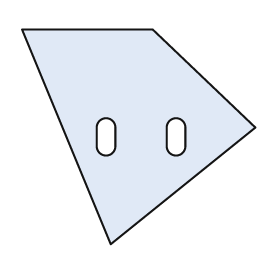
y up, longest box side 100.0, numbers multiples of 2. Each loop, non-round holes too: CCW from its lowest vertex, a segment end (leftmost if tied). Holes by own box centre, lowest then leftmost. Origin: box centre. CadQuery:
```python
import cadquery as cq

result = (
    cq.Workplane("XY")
    .moveTo(-12.0, -46.0)
    .lineTo(50.0, 4.0)
    .lineTo(6.0, 46.0)
    .lineTo(-50.0, 46.0)
    .close()
    .moveTo(-18.0, -4.0)
    .threePointArc((-14.0, -8.0), (-10.0, -4.0))
    .lineTo(-10.0, 4.0)
    .threePointArc((-14.0, 8.0), (-18.0, 4.0))
    .close()
    .moveTo(12.0, -4.0)
    .threePointArc((16.0, -8.0), (20.0, -4.0))
    .lineTo(20.0, 4.0)
    .threePointArc((16.0, 8.0), (12.0, 4.0))
    .close()
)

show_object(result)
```